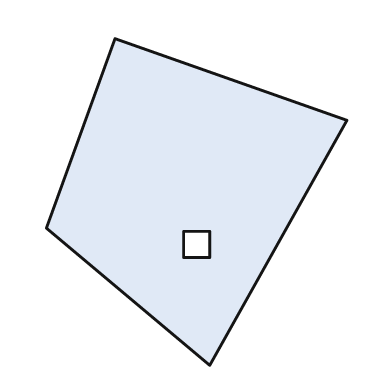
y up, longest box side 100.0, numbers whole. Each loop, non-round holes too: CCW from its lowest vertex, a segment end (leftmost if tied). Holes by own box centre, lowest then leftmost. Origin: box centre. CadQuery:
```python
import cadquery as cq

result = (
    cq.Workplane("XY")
    .moveTo(4.0, -50.0)
    .lineTo(46.0, 25.0)
    .lineTo(-25.0, 50.0)
    .lineTo(-46.0, -8.0)
    .close()
    .moveTo(-4.0, -17.0)
    .lineTo(4.0, -17.0)
    .lineTo(4.0, -9.0)
    .lineTo(-4.0, -9.0)
    .close()
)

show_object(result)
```